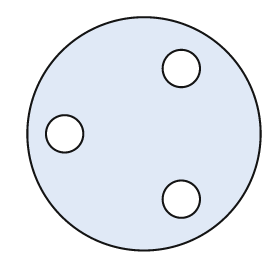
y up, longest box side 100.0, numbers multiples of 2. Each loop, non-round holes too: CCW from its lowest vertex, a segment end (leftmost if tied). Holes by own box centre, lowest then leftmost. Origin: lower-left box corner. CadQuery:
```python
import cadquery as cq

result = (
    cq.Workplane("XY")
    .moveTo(50.0, 50.0)
    .circle(50.0)
    .moveTo(66.0, 22.0)
    .circle(8.0)
    .moveTo(16.0, 50.0)
    .circle(8.0)
    .moveTo(66.0, 78.0)
    .circle(8.0)
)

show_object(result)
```